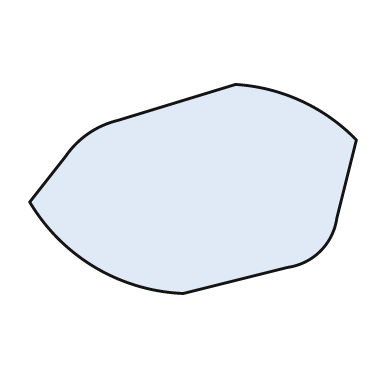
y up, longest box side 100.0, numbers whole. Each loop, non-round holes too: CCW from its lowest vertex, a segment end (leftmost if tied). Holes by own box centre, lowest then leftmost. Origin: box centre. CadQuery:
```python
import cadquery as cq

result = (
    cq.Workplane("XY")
    .moveTo(-3.0, -32.0)
    .lineTo(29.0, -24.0)
    .threePointArc((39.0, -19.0), (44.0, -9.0))
    .lineTo(50.0, 15.0)
    .threePointArc((33.0, 27.0), (13.0, 32.0))
    .lineTo(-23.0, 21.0)
    .threePointArc((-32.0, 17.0), (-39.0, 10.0))
    .lineTo(-50.0, -4.0)
    .threePointArc((-30.0, -24.0), (-3.0, -32.0))
    .close()
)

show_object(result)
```